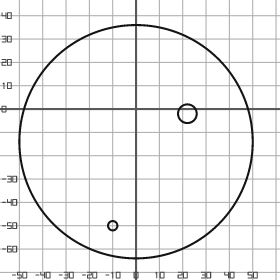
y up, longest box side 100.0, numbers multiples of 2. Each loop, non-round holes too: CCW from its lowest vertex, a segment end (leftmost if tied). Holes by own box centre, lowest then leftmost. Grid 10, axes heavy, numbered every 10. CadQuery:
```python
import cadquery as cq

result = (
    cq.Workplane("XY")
    .moveTo(0.0, -14.0)
    .circle(50.0)
    .moveTo(-10.0, -50.0)
    .circle(2.0)
    .moveTo(22.0, -2.0)
    .circle(4.0)
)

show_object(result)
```